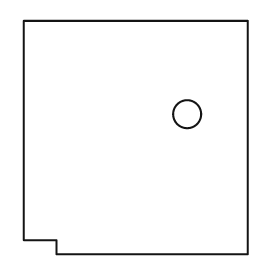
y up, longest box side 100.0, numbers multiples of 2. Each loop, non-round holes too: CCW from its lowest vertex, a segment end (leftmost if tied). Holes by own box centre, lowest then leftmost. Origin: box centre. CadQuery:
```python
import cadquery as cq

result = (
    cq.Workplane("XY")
    .moveTo(-34.0, -50.0)
    .lineTo(48.0, -50.0)
    .lineTo(48.0, 50.0)
    .lineTo(-48.0, 50.0)
    .lineTo(-48.0, -44.0)
    .lineTo(-34.0, -44.0)
    .close()
    .moveTo(22.0, 10.0)
    .circle(6.0)
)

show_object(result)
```